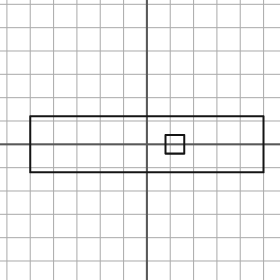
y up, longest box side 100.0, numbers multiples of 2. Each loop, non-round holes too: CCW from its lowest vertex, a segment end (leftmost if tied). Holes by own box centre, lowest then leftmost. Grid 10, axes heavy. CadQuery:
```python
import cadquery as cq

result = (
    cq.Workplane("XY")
    .moveTo(-50.0, -12.0)
    .lineTo(50.0, -12.0)
    .lineTo(50.0, 12.0)
    .lineTo(-50.0, 12.0)
    .close()
    .moveTo(8.0, -4.0)
    .lineTo(16.0, -4.0)
    .lineTo(16.0, 4.0)
    .lineTo(8.0, 4.0)
    .close()
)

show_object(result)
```